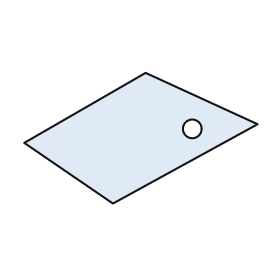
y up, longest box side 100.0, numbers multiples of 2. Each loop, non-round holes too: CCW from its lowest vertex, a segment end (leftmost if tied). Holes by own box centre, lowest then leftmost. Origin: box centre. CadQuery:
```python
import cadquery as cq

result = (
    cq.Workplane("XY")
    .moveTo(-12.0, -28.0)
    .lineTo(50.0, 6.0)
    .lineTo(2.0, 28.0)
    .lineTo(-50.0, -2.0)
    .close()
    .moveTo(22.0, 4.0)
    .circle(4.0)
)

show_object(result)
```